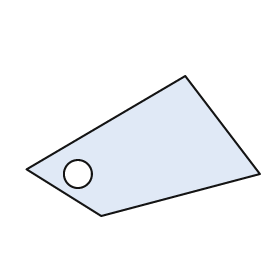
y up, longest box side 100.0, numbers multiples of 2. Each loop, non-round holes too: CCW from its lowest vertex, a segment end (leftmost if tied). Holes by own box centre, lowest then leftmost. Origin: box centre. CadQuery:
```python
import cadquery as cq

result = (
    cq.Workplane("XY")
    .moveTo(-18.0, -30.0)
    .lineTo(50.0, -12.0)
    .lineTo(18.0, 30.0)
    .lineTo(-50.0, -10.0)
    .close()
    .moveTo(-28.0, -12.0)
    .circle(6.0)
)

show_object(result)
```